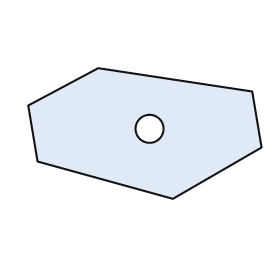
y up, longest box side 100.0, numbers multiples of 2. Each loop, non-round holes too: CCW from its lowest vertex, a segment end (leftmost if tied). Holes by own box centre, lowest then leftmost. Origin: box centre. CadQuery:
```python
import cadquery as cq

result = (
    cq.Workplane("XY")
    .moveTo(12.0, -28.0)
    .lineTo(50.0, -6.0)
    .lineTo(46.0, 18.0)
    .lineTo(-20.0, 28.0)
    .lineTo(-50.0, 12.0)
    .lineTo(-46.0, -12.0)
    .close()
    .moveTo(2.0, 2.0)
    .circle(6.0)
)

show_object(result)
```